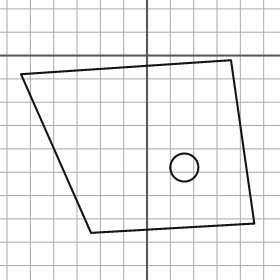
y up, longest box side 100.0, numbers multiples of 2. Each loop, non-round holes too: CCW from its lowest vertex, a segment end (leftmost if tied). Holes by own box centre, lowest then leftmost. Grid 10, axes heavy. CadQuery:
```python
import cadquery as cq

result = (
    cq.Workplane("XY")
    .moveTo(-24.0, -76.0)
    .lineTo(46.0, -72.0)
    .lineTo(36.0, -2.0)
    .lineTo(-54.0, -8.0)
    .close()
    .moveTo(16.0, -48.0)
    .circle(6.0)
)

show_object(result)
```